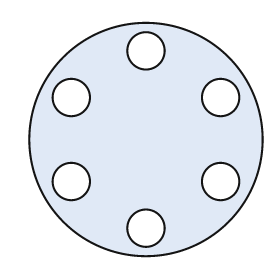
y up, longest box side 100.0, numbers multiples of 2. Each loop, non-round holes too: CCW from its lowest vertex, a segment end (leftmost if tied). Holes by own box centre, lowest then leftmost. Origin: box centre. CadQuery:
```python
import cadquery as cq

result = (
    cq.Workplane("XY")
    .moveTo(0.0, 0.0)
    .circle(50.0)
    .moveTo(0.0, -38.0)
    .circle(8.0)
    .moveTo(-32.0, -18.0)
    .circle(8.0)
    .moveTo(32.0, -18.0)
    .circle(8.0)
    .moveTo(-32.0, 18.0)
    .circle(8.0)
    .moveTo(32.0, 18.0)
    .circle(8.0)
    .moveTo(0.0, 38.0)
    .circle(8.0)
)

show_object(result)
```